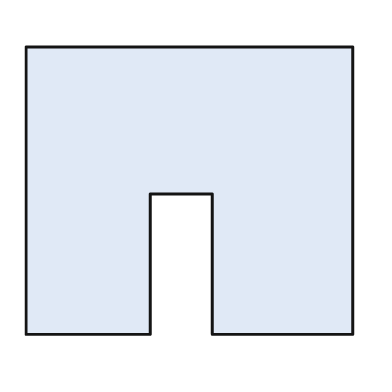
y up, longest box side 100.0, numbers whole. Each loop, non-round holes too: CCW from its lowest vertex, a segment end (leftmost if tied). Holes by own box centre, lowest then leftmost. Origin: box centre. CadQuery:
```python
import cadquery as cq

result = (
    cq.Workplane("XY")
    .moveTo(-50.0, -44.0)
    .lineTo(-12.0, -44.0)
    .lineTo(-12.0, -1.0)
    .lineTo(7.0, -1.0)
    .lineTo(7.0, -44.0)
    .lineTo(50.0, -44.0)
    .lineTo(50.0, 44.0)
    .lineTo(-50.0, 44.0)
    .close()
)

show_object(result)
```